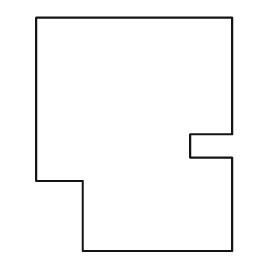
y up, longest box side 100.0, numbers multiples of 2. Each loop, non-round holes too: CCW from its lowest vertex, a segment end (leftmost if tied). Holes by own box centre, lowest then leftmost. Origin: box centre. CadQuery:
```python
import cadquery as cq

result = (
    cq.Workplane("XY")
    .moveTo(-22.0, -50.0)
    .lineTo(42.0, -50.0)
    .lineTo(42.0, -10.0)
    .lineTo(24.0, -10.0)
    .lineTo(24.0, 0.0)
    .lineTo(42.0, 0.0)
    .lineTo(42.0, 50.0)
    .lineTo(-42.0, 50.0)
    .lineTo(-42.0, -20.0)
    .lineTo(-22.0, -20.0)
    .close()
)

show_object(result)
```